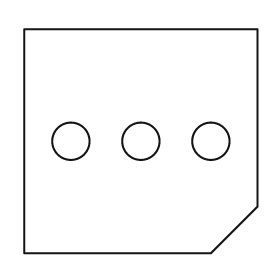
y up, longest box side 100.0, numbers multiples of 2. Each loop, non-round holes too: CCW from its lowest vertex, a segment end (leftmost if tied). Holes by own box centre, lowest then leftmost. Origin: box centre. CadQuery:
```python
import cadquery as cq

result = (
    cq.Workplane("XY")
    .moveTo(-50.0, -48.0)
    .lineTo(30.0, -48.0)
    .lineTo(50.0, -28.0)
    .lineTo(50.0, 48.0)
    .lineTo(-50.0, 48.0)
    .close()
    .moveTo(-30.0, 0.0)
    .circle(8.0)
    .moveTo(0.0, 0.0)
    .circle(8.0)
    .moveTo(30.0, 0.0)
    .circle(8.0)
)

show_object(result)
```